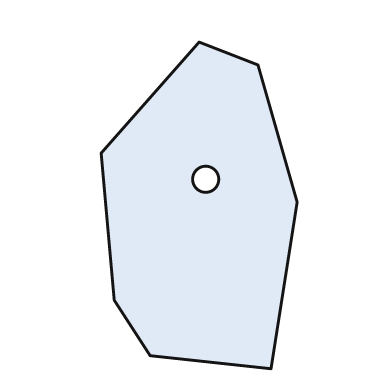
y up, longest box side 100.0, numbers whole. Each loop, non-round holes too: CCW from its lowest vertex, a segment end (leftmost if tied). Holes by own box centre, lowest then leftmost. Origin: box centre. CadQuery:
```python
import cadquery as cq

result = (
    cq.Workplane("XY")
    .moveTo(22.0, -50.0)
    .lineTo(30.0, 1.0)
    .lineTo(18.0, 43.0)
    .lineTo(0.0, 50.0)
    .lineTo(-30.0, 16.0)
    .lineTo(-26.0, -29.0)
    .lineTo(-15.0, -46.0)
    .close()
    .moveTo(2.0, 8.0)
    .circle(4.0)
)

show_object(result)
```